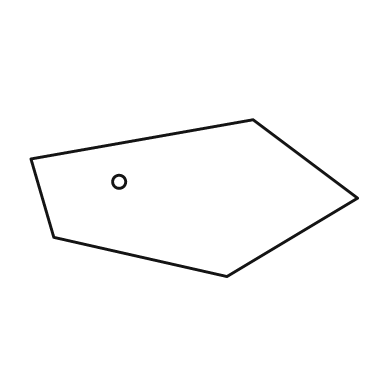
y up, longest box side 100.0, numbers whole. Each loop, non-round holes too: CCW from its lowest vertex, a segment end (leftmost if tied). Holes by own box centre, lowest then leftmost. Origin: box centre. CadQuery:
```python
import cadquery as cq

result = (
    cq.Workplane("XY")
    .moveTo(10.0, -24.0)
    .lineTo(50.0, 0.0)
    .lineTo(18.0, 24.0)
    .lineTo(-50.0, 12.0)
    .lineTo(-43.0, -12.0)
    .close()
    .moveTo(-23.0, 5.0)
    .circle(2.0)
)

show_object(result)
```